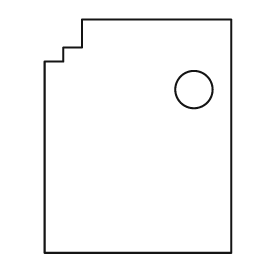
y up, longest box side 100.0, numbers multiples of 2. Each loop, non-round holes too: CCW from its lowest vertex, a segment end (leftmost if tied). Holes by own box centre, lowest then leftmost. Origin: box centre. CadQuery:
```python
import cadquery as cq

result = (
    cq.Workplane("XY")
    .moveTo(-40.0, -50.0)
    .lineTo(40.0, -50.0)
    .lineTo(40.0, 50.0)
    .lineTo(-24.0, 50.0)
    .lineTo(-24.0, 38.0)
    .lineTo(-32.0, 38.0)
    .lineTo(-32.0, 32.0)
    .lineTo(-40.0, 32.0)
    .close()
    .moveTo(24.0, 20.0)
    .circle(8.0)
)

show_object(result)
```